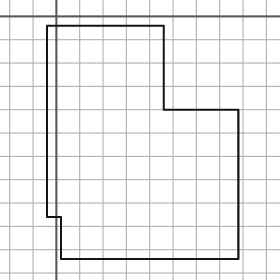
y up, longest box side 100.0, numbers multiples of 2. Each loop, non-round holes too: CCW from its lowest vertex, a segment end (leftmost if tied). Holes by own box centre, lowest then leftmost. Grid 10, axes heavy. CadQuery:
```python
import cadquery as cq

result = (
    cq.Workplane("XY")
    .moveTo(2.0, -104.0)
    .lineTo(78.0, -104.0)
    .lineTo(78.0, -40.0)
    .lineTo(46.0, -40.0)
    .lineTo(46.0, -4.0)
    .lineTo(-4.0, -4.0)
    .lineTo(-4.0, -86.0)
    .lineTo(2.0, -86.0)
    .close()
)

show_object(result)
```